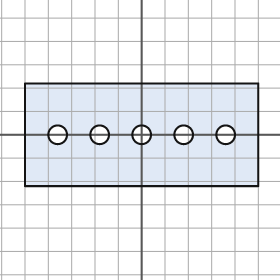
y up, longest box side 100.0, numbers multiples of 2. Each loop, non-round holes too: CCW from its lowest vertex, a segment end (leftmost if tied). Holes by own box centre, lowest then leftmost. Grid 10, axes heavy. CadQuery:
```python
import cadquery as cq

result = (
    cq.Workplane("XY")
    .moveTo(-50.0, -22.0)
    .lineTo(50.0, -22.0)
    .lineTo(50.0, 22.0)
    .lineTo(-50.0, 22.0)
    .close()
    .moveTo(-36.0, 0.0)
    .circle(4.0)
    .moveTo(-18.0, 0.0)
    .circle(4.0)
    .moveTo(0.0, 0.0)
    .circle(4.0)
    .moveTo(18.0, 0.0)
    .circle(4.0)
    .moveTo(36.0, 0.0)
    .circle(4.0)
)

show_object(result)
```